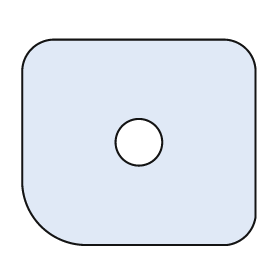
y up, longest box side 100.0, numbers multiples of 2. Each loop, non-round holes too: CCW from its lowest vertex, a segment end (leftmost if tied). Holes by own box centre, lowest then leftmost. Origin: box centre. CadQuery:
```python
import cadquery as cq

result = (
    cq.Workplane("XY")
    .moveTo(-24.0, -44.0)
    .lineTo(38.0, -44.0)
    .threePointArc((46.0, -40.0), (50.0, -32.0))
    .lineTo(50.0, 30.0)
    .threePointArc((46.0, 40.0), (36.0, 44.0))
    .lineTo(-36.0, 44.0)
    .threePointArc((-46.0, 40.0), (-50.0, 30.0))
    .lineTo(-50.0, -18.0)
    .threePointArc((-42.0, -36.0), (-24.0, -44.0))
    .close()
    .moveTo(0.0, 0.0)
    .circle(10.0)
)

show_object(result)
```